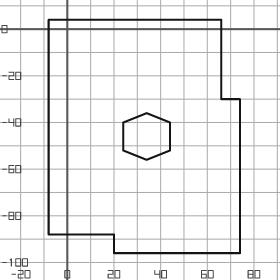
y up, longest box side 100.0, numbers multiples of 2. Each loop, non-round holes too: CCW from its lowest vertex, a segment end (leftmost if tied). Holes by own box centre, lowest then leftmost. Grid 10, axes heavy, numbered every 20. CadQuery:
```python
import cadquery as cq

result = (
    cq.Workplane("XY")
    .moveTo(20.0, -96.0)
    .lineTo(74.0, -96.0)
    .lineTo(74.0, -30.0)
    .lineTo(66.0, -30.0)
    .lineTo(66.0, 4.0)
    .lineTo(-8.0, 4.0)
    .lineTo(-8.0, -88.0)
    .lineTo(20.0, -88.0)
    .close()
    .moveTo(34.0, -56.0)
    .lineTo(44.0, -52.0)
    .lineTo(44.0, -40.0)
    .lineTo(34.0, -36.0)
    .lineTo(24.0, -40.0)
    .lineTo(24.0, -52.0)
    .close()
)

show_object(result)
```